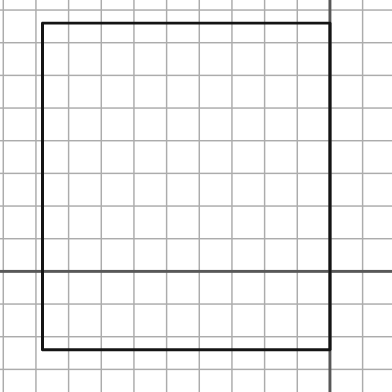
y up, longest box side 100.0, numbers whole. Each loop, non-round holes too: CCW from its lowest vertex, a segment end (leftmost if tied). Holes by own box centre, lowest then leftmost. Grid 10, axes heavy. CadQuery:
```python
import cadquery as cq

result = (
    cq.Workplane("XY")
    .moveTo(-88.0, -24.0)
    .lineTo(0.0, -24.0)
    .lineTo(0.0, 76.0)
    .lineTo(-88.0, 76.0)
    .close()
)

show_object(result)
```